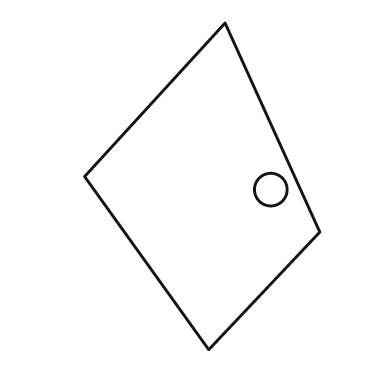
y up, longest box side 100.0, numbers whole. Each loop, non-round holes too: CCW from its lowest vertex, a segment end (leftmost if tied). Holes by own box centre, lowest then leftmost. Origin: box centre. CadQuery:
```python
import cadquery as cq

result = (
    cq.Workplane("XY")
    .moveTo(2.0, -50.0)
    .lineTo(36.0, -14.0)
    .lineTo(7.0, 50.0)
    .lineTo(-36.0, 3.0)
    .close()
    .moveTo(21.0, -1.0)
    .circle(5.0)
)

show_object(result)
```